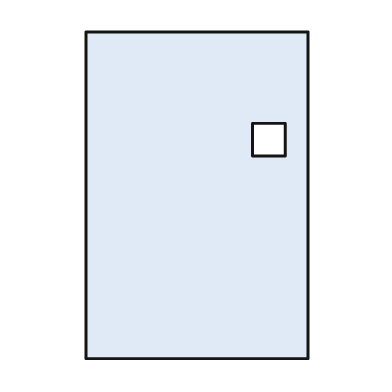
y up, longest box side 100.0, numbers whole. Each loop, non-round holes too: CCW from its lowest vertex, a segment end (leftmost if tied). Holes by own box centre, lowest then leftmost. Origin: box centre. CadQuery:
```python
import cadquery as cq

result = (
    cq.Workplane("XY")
    .moveTo(-34.0, -50.0)
    .lineTo(34.0, -50.0)
    .lineTo(34.0, 50.0)
    .lineTo(-34.0, 50.0)
    .close()
    .moveTo(17.0, 12.0)
    .lineTo(27.0, 12.0)
    .lineTo(27.0, 22.0)
    .lineTo(17.0, 22.0)
    .close()
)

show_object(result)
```